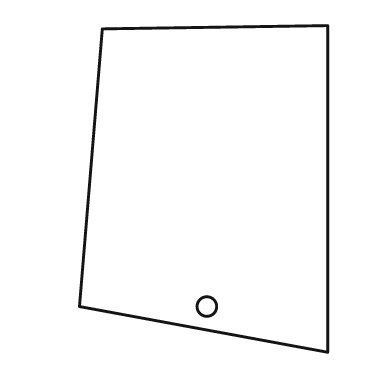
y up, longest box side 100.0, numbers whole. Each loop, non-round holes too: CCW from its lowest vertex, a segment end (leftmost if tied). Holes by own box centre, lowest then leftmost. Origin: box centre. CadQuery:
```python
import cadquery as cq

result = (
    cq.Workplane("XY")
    .moveTo(38.0, -50.0)
    .lineTo(38.0, 50.0)
    .lineTo(-31.0, 49.0)
    .lineTo(-38.0, -36.0)
    .close()
    .moveTo(1.0, -36.0)
    .circle(3.0)
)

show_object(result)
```